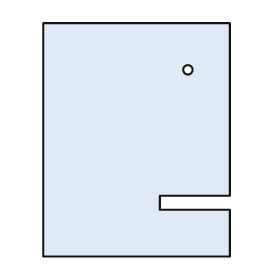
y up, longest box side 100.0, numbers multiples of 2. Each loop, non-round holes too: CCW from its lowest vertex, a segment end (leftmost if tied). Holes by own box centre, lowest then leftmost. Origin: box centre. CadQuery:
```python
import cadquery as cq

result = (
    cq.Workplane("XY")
    .moveTo(-40.0, -50.0)
    .lineTo(40.0, -50.0)
    .lineTo(40.0, -30.0)
    .lineTo(10.0, -30.0)
    .lineTo(10.0, -24.0)
    .lineTo(40.0, -24.0)
    .lineTo(40.0, 50.0)
    .lineTo(-40.0, 50.0)
    .close()
    .moveTo(22.0, 30.0)
    .circle(2.0)
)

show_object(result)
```